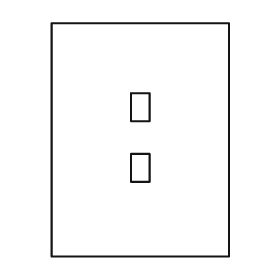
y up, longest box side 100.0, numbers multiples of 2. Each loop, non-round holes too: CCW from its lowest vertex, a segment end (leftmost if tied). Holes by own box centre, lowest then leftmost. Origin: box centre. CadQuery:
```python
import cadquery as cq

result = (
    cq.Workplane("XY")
    .moveTo(-38.0, -50.0)
    .lineTo(38.0, -50.0)
    .lineTo(38.0, 50.0)
    .lineTo(-38.0, 50.0)
    .close()
    .moveTo(-4.0, -18.0)
    .lineTo(4.0, -18.0)
    .lineTo(4.0, -6.0)
    .lineTo(-4.0, -6.0)
    .close()
    .moveTo(-4.0, 8.0)
    .lineTo(4.0, 8.0)
    .lineTo(4.0, 20.0)
    .lineTo(-4.0, 20.0)
    .close()
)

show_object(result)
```